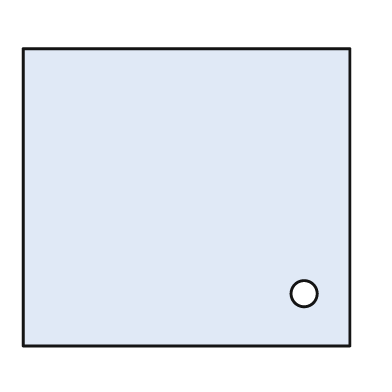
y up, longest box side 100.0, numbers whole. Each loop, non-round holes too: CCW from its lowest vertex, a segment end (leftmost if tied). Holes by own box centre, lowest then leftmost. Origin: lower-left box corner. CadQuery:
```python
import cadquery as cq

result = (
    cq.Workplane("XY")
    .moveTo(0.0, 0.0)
    .lineTo(100.0, 0.0)
    .lineTo(100.0, 91.0)
    .lineTo(0.0, 91.0)
    .close()
    .moveTo(86.0, 16.0)
    .circle(4.0)
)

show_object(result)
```